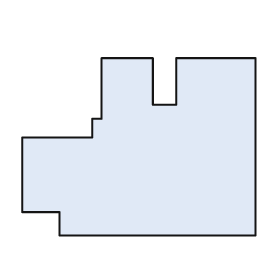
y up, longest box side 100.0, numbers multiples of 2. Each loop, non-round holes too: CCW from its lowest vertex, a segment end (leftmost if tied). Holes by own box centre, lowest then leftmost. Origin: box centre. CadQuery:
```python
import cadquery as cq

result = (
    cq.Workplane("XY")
    .moveTo(-34.0, -38.0)
    .lineTo(50.0, -38.0)
    .lineTo(50.0, 38.0)
    .lineTo(16.0, 38.0)
    .lineTo(16.0, 18.0)
    .lineTo(6.0, 18.0)
    .lineTo(6.0, 38.0)
    .lineTo(-16.0, 38.0)
    .lineTo(-16.0, 12.0)
    .lineTo(-20.0, 12.0)
    .lineTo(-20.0, 4.0)
    .lineTo(-50.0, 4.0)
    .lineTo(-50.0, -28.0)
    .lineTo(-34.0, -28.0)
    .close()
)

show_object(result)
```